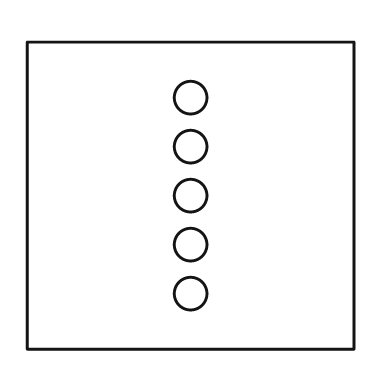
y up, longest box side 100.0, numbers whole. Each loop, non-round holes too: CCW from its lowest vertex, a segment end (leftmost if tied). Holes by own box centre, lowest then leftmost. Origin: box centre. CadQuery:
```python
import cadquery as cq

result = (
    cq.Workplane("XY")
    .moveTo(-50.0, -47.0)
    .lineTo(50.0, -47.0)
    .lineTo(50.0, 47.0)
    .lineTo(-50.0, 47.0)
    .close()
    .moveTo(0.0, -30.0)
    .circle(5.0)
    .moveTo(0.0, -15.0)
    .circle(5.0)
    .moveTo(0.0, 0.0)
    .circle(5.0)
    .moveTo(0.0, 15.0)
    .circle(5.0)
    .moveTo(0.0, 30.0)
    .circle(5.0)
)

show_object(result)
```